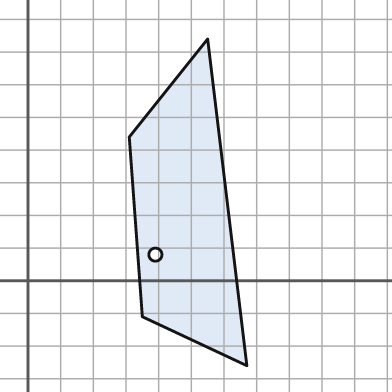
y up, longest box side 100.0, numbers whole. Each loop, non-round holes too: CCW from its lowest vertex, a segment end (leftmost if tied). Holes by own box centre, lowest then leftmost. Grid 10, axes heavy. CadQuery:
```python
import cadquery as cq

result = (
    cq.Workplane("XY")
    .moveTo(67.0, -26.0)
    .lineTo(55.0, 74.0)
    .lineTo(31.0, 44.0)
    .lineTo(35.0, -11.0)
    .close()
    .moveTo(39.0, 8.0)
    .circle(2.0)
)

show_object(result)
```